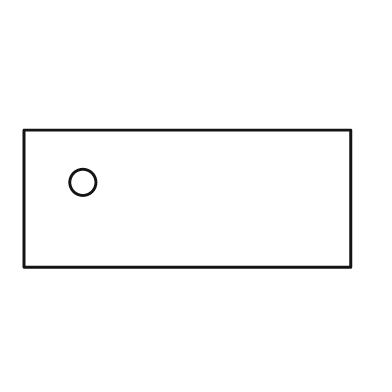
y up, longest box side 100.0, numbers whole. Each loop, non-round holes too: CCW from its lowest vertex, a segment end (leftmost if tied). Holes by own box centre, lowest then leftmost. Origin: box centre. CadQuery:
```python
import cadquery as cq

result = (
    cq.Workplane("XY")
    .moveTo(-50.0, -21.0)
    .lineTo(50.0, -21.0)
    .lineTo(50.0, 21.0)
    .lineTo(-50.0, 21.0)
    .close()
    .moveTo(-32.0, 5.0)
    .circle(4.0)
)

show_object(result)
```